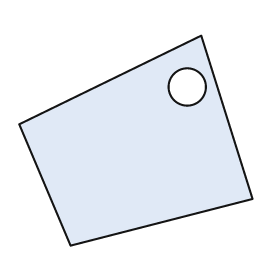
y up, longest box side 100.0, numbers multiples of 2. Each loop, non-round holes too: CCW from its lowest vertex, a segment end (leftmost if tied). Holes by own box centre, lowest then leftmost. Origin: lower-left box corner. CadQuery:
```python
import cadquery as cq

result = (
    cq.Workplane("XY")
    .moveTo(22.0, 0.0)
    .lineTo(100.0, 20.0)
    .lineTo(78.0, 90.0)
    .lineTo(0.0, 52.0)
    .close()
    .moveTo(72.0, 68.0)
    .circle(8.0)
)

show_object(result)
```